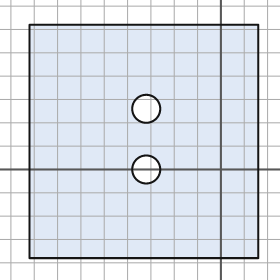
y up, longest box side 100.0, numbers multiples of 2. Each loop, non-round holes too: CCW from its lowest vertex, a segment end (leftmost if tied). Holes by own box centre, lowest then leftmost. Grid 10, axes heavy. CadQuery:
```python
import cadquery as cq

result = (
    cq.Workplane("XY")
    .moveTo(-82.0, -38.0)
    .lineTo(16.0, -38.0)
    .lineTo(16.0, 62.0)
    .lineTo(-82.0, 62.0)
    .close()
    .moveTo(-32.0, 0.0)
    .circle(6.0)
    .moveTo(-32.0, 26.0)
    .circle(6.0)
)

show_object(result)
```